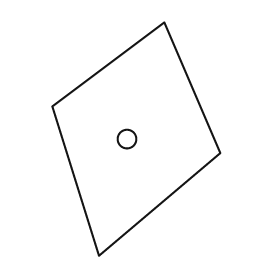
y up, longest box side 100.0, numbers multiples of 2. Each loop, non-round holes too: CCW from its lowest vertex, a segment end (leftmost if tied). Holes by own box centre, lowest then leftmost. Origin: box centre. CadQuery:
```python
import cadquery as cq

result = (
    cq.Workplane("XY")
    .moveTo(-16.0, -50.0)
    .lineTo(36.0, -6.0)
    .lineTo(12.0, 50.0)
    .lineTo(-36.0, 14.0)
    .close()
    .moveTo(-4.0, 0.0)
    .circle(4.0)
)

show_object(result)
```